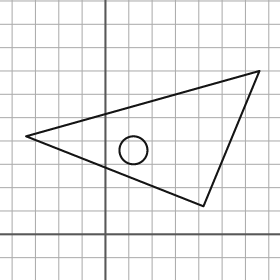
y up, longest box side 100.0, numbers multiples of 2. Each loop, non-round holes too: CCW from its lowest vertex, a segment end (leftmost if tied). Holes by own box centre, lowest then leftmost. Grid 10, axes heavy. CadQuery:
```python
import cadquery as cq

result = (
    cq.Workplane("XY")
    .moveTo(42.0, 12.0)
    .lineTo(66.0, 70.0)
    .lineTo(-34.0, 42.0)
    .close()
    .moveTo(12.0, 36.0)
    .circle(6.0)
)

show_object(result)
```